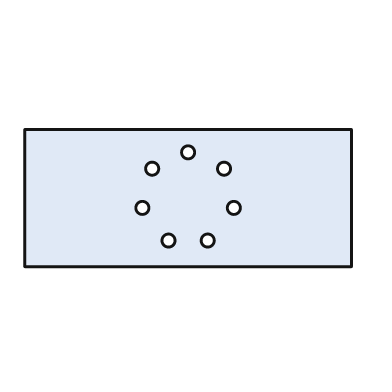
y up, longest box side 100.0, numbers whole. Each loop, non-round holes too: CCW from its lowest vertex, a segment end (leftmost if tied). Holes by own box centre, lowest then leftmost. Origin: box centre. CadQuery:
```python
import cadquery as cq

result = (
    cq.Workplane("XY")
    .moveTo(-50.0, -21.0)
    .lineTo(50.0, -21.0)
    .lineTo(50.0, 21.0)
    .lineTo(-50.0, 21.0)
    .close()
    .moveTo(-6.0, -13.0)
    .circle(2.0)
    .moveTo(6.0, -13.0)
    .circle(2.0)
    .moveTo(-14.0, -3.0)
    .circle(2.0)
    .moveTo(14.0, -3.0)
    .circle(2.0)
    .moveTo(-11.0, 9.0)
    .circle(2.0)
    .moveTo(11.0, 9.0)
    .circle(2.0)
    .moveTo(0.0, 14.0)
    .circle(2.0)
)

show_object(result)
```